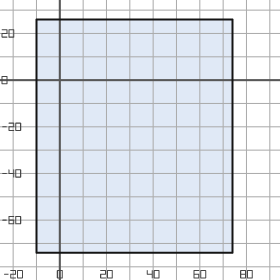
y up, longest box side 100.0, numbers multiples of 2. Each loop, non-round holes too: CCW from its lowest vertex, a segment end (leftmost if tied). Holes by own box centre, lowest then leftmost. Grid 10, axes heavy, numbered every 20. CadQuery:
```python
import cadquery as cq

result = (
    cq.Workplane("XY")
    .moveTo(-10.0, -74.0)
    .lineTo(74.0, -74.0)
    .lineTo(74.0, 26.0)
    .lineTo(-10.0, 26.0)
    .close()
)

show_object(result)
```